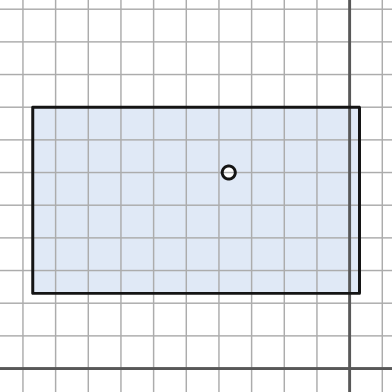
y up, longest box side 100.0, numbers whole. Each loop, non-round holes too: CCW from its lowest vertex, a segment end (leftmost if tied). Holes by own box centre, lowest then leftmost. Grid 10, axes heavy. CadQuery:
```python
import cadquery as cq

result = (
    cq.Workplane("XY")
    .moveTo(-97.0, 23.0)
    .lineTo(3.0, 23.0)
    .lineTo(3.0, 80.0)
    .lineTo(-97.0, 80.0)
    .close()
    .moveTo(-37.0, 60.0)
    .circle(2.0)
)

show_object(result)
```